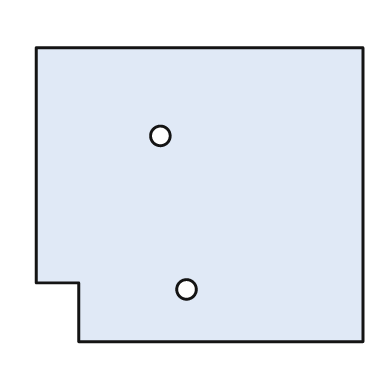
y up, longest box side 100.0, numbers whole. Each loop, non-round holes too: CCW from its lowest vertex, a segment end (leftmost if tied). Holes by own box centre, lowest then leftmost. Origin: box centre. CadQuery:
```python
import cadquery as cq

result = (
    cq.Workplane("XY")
    .moveTo(-37.0, -45.0)
    .lineTo(50.0, -45.0)
    .lineTo(50.0, 45.0)
    .lineTo(-50.0, 45.0)
    .lineTo(-50.0, -27.0)
    .lineTo(-37.0, -27.0)
    .close()
    .moveTo(-4.0, -29.0)
    .circle(3.0)
    .moveTo(-12.0, 18.0)
    .circle(3.0)
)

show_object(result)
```